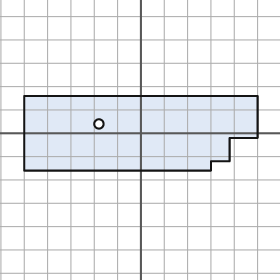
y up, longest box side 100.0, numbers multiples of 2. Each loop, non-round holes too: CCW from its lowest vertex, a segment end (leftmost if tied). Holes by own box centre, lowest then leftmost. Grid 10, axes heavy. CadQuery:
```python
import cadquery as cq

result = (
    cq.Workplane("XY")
    .moveTo(-50.0, -16.0)
    .lineTo(30.0, -16.0)
    .lineTo(30.0, -12.0)
    .lineTo(38.0, -12.0)
    .lineTo(38.0, -2.0)
    .lineTo(50.0, -2.0)
    .lineTo(50.0, 16.0)
    .lineTo(-50.0, 16.0)
    .close()
    .moveTo(-18.0, 4.0)
    .circle(2.0)
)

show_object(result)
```